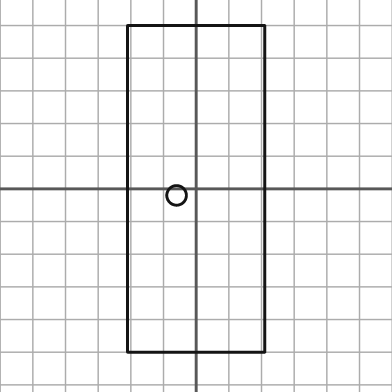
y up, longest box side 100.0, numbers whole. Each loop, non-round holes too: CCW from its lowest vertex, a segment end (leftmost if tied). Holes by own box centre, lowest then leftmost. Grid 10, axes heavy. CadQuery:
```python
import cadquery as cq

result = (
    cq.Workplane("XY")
    .moveTo(-21.0, -50.0)
    .lineTo(21.0, -50.0)
    .lineTo(21.0, 50.0)
    .lineTo(-21.0, 50.0)
    .close()
    .moveTo(-6.0, -2.0)
    .circle(3.0)
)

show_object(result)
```